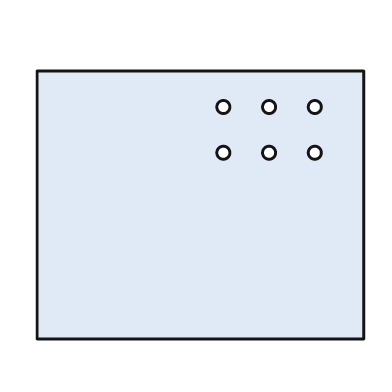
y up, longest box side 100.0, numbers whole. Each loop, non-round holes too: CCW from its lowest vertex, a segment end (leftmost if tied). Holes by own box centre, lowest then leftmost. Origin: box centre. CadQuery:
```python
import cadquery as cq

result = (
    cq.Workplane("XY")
    .moveTo(-50.0, -41.0)
    .lineTo(50.0, -41.0)
    .lineTo(50.0, 41.0)
    .lineTo(-50.0, 41.0)
    .close()
    .moveTo(7.0, 16.0)
    .circle(2.0)
    .moveTo(21.0, 16.0)
    .circle(2.0)
    .moveTo(35.0, 16.0)
    .circle(2.0)
    .moveTo(7.0, 30.0)
    .circle(2.0)
    .moveTo(21.0, 30.0)
    .circle(2.0)
    .moveTo(35.0, 30.0)
    .circle(2.0)
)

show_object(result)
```